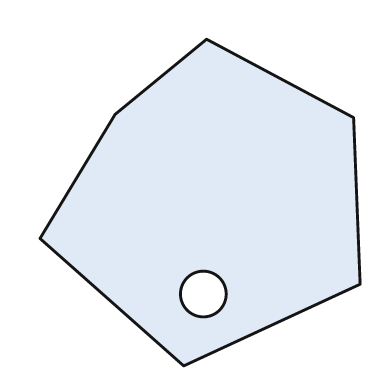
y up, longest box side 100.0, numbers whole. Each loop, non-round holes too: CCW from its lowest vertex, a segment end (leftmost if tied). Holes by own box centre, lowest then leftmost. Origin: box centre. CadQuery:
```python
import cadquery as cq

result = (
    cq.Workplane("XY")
    .moveTo(-5.0, -50.0)
    .lineTo(49.0, -25.0)
    .lineTo(47.0, 26.0)
    .lineTo(2.0, 50.0)
    .lineTo(-26.0, 27.0)
    .lineTo(-49.0, -11.0)
    .close()
    .moveTo(1.0, -28.0)
    .circle(7.0)
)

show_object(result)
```